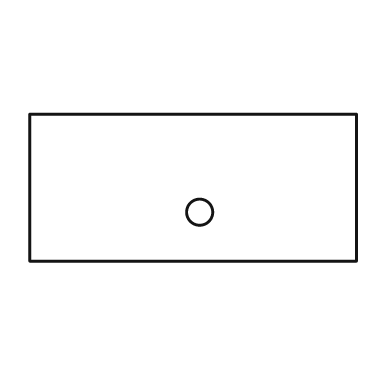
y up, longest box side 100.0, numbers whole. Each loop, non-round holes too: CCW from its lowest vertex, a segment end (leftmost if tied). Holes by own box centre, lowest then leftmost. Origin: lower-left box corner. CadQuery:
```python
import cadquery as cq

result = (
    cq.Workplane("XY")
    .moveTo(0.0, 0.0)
    .lineTo(100.0, 0.0)
    .lineTo(100.0, 45.0)
    .lineTo(0.0, 45.0)
    .close()
    .moveTo(52.0, 15.0)
    .circle(4.0)
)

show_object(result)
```